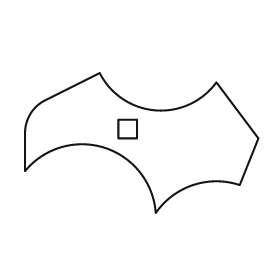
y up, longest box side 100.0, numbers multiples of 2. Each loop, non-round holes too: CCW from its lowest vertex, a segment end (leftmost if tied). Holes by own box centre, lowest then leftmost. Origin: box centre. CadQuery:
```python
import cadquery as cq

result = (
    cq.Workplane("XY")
    .moveTo(6.0, -30.0)
    .threePointArc((22.0, -18.0), (42.0, -18.0))
    .lineTo(50.0, 2.0)
    .lineTo(32.0, 26.0)
    .threePointArc((6.0, 14.0), (-18.0, 30.0))
    .lineTo(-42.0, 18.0)
    .threePointArc((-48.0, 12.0), (-50.0, 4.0))
    .lineTo(-50.0, -12.0)
    .threePointArc((-16.0, -2.0), (6.0, -30.0))
    .close()
    .moveTo(-10.0, 2.0)
    .lineTo(-2.0, 2.0)
    .lineTo(-2.0, 10.0)
    .lineTo(-10.0, 10.0)
    .close()
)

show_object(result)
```